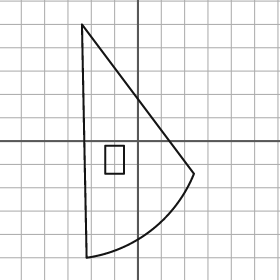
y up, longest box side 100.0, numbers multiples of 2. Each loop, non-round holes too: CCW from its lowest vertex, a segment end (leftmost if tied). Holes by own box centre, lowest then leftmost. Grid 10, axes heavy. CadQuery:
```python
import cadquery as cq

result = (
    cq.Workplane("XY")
    .moveTo(-22.0, -50.0)
    .threePointArc((6.0, -38.0), (24.0, -14.0))
    .lineTo(-24.0, 50.0)
    .close()
    .moveTo(-14.0, -14.0)
    .lineTo(-6.0, -14.0)
    .lineTo(-6.0, -2.0)
    .lineTo(-14.0, -2.0)
    .close()
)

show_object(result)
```